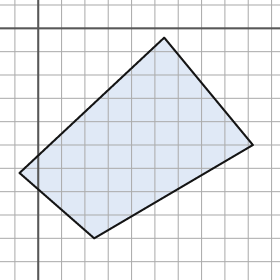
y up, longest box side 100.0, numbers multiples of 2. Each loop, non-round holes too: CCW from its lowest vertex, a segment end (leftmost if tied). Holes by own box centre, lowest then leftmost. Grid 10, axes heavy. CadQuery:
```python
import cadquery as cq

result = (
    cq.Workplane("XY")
    .moveTo(24.0, -90.0)
    .lineTo(92.0, -50.0)
    .lineTo(54.0, -4.0)
    .lineTo(-8.0, -62.0)
    .close()
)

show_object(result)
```